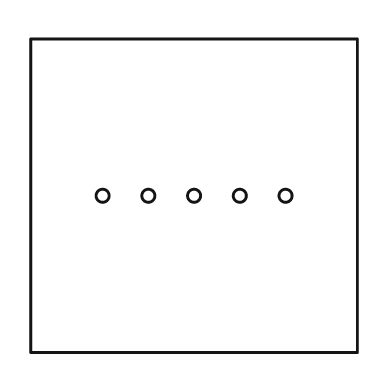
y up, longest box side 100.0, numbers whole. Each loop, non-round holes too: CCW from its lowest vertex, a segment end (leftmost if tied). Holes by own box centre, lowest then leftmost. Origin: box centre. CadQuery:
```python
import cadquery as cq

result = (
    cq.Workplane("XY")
    .moveTo(-50.0, -48.0)
    .lineTo(50.0, -48.0)
    .lineTo(50.0, 48.0)
    .lineTo(-50.0, 48.0)
    .close()
    .moveTo(-28.0, 0.0)
    .circle(2.0)
    .moveTo(-14.0, 0.0)
    .circle(2.0)
    .moveTo(0.0, 0.0)
    .circle(2.0)
    .moveTo(14.0, 0.0)
    .circle(2.0)
    .moveTo(28.0, 0.0)
    .circle(2.0)
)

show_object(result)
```